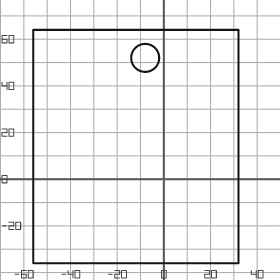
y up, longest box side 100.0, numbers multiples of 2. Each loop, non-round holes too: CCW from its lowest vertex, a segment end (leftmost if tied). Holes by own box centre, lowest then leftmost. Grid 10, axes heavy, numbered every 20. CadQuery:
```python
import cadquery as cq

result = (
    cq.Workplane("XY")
    .moveTo(-56.0, -36.0)
    .lineTo(32.0, -36.0)
    .lineTo(32.0, 64.0)
    .lineTo(-56.0, 64.0)
    .close()
    .moveTo(-8.0, 52.0)
    .circle(6.0)
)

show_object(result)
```